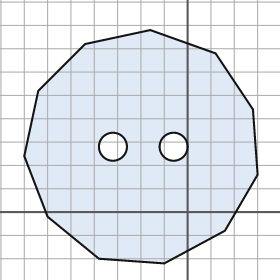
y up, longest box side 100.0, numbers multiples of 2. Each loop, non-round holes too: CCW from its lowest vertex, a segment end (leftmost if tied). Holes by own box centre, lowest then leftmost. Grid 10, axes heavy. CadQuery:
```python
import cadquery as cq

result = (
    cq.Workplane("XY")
    .moveTo(-10.0, -22.0)
    .lineTo(16.0, -8.0)
    .lineTo(30.0, 16.0)
    .lineTo(28.0, 44.0)
    .lineTo(12.0, 68.0)
    .lineTo(-16.0, 78.0)
    .lineTo(-44.0, 72.0)
    .lineTo(-64.0, 52.0)
    .lineTo(-70.0, 24.0)
    .lineTo(-60.0, -2.0)
    .lineTo(-38.0, -20.0)
    .close()
    .moveTo(-32.0, 28.0)
    .circle(6.0)
    .moveTo(-6.0, 28.0)
    .circle(6.0)
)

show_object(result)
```